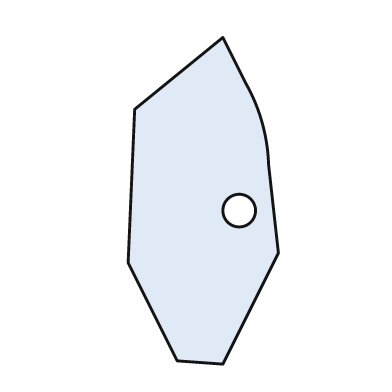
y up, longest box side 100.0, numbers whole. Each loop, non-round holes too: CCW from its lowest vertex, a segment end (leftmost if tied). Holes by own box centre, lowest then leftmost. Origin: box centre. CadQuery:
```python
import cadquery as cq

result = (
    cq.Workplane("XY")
    .moveTo(6.0, -50.0)
    .lineTo(23.0, -16.0)
    .lineTo(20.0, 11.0)
    .threePointArc((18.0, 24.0), (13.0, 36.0))
    .lineTo(6.0, 50.0)
    .lineTo(-21.0, 28.0)
    .lineTo(-23.0, -19.0)
    .lineTo(-8.0, -49.0)
    .close()
    .moveTo(11.0, -3.0)
    .circle(5.0)
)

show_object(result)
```